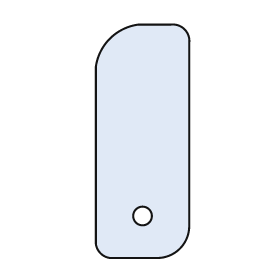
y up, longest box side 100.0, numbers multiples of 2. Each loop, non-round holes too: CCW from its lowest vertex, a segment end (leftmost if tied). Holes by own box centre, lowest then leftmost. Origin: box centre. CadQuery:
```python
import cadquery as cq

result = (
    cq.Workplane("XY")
    .moveTo(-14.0, -50.0)
    .lineTo(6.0, -50.0)
    .threePointArc((16.0, -46.0), (20.0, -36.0))
    .lineTo(20.0, 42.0)
    .threePointArc((18.0, 48.0), (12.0, 50.0))
    .lineTo(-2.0, 50.0)
    .threePointArc((-14.0, 44.0), (-20.0, 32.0))
    .lineTo(-20.0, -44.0)
    .threePointArc((-18.0, -48.0), (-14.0, -50.0))
    .close()
    .moveTo(0.0, -32.0)
    .circle(4.0)
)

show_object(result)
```